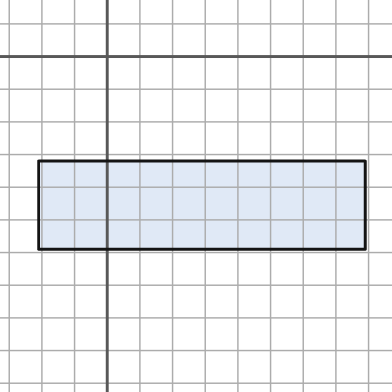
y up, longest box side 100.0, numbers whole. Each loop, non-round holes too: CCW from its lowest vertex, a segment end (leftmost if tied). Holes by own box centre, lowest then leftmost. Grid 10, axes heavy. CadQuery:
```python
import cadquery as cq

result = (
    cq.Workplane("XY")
    .moveTo(-21.0, -59.0)
    .lineTo(79.0, -59.0)
    .lineTo(79.0, -32.0)
    .lineTo(-21.0, -32.0)
    .close()
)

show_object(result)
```